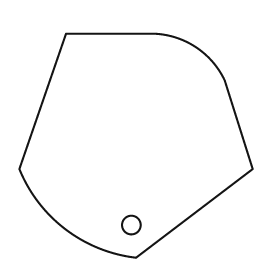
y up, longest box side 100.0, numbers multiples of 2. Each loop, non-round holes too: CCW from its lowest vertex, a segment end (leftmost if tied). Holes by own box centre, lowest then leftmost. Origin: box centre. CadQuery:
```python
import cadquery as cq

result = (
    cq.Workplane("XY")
    .moveTo(0.0, -48.0)
    .lineTo(50.0, -10.0)
    .lineTo(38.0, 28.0)
    .threePointArc((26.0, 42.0), (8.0, 48.0))
    .lineTo(-30.0, 48.0)
    .lineTo(-50.0, -10.0)
    .threePointArc((-30.0, -36.0), (0.0, -48.0))
    .close()
    .moveTo(-2.0, -34.0)
    .circle(4.0)
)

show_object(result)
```